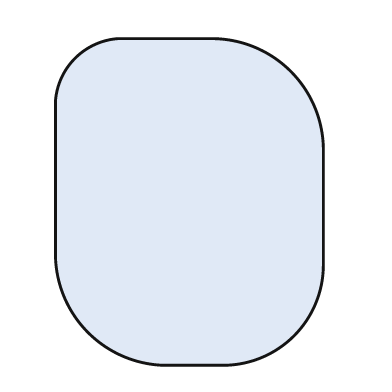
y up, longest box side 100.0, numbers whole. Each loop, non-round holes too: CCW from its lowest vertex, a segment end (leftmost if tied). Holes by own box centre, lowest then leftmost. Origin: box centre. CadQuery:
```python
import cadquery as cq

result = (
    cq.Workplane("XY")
    .moveTo(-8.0, -50.0)
    .lineTo(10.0, -50.0)
    .threePointArc((32.0, -41.0), (41.0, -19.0))
    .lineTo(41.0, 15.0)
    .threePointArc((31.0, 40.0), (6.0, 50.0))
    .lineTo(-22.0, 50.0)
    .threePointArc((-35.0, 44.0), (-41.0, 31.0))
    .lineTo(-41.0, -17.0)
    .threePointArc((-31.0, -40.0), (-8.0, -50.0))
    .close()
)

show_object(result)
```